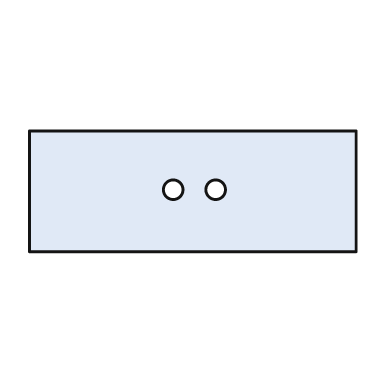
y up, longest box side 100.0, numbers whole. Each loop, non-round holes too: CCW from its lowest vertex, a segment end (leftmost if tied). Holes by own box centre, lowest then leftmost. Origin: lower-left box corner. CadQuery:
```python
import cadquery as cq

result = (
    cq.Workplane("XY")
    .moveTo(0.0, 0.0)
    .lineTo(100.0, 0.0)
    .lineTo(100.0, 37.0)
    .lineTo(0.0, 37.0)
    .close()
    .moveTo(44.0, 19.0)
    .circle(3.0)
    .moveTo(57.0, 19.0)
    .circle(3.0)
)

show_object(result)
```